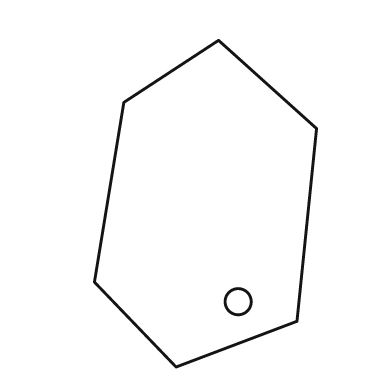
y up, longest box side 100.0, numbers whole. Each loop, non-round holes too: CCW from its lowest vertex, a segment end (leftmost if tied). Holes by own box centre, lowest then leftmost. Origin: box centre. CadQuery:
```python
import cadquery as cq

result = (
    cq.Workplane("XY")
    .moveTo(-9.0, -50.0)
    .lineTo(28.0, -36.0)
    .lineTo(34.0, 23.0)
    .lineTo(4.0, 50.0)
    .lineTo(-25.0, 31.0)
    .lineTo(-34.0, -24.0)
    .close()
    .moveTo(10.0, -30.0)
    .circle(4.0)
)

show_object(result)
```